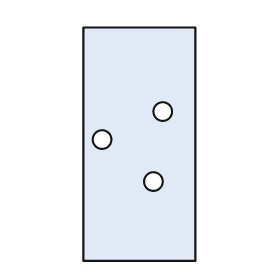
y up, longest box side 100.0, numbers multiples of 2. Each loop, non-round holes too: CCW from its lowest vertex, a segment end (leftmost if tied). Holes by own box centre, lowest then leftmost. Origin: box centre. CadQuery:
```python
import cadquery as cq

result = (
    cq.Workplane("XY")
    .moveTo(-24.0, -50.0)
    .lineTo(24.0, -50.0)
    .lineTo(24.0, 50.0)
    .lineTo(-24.0, 50.0)
    .close()
    .moveTo(6.0, -16.0)
    .circle(4.0)
    .moveTo(-16.0, 2.0)
    .circle(4.0)
    .moveTo(10.0, 14.0)
    .circle(4.0)
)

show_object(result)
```